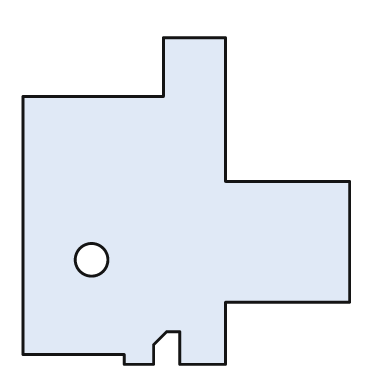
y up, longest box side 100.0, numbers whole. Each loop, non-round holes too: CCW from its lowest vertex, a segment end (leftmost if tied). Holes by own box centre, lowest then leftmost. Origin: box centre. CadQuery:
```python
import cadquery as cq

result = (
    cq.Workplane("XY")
    .moveTo(-19.0, -50.0)
    .lineTo(-10.0, -50.0)
    .lineTo(-10.0, -44.0)
    .lineTo(-6.0, -40.0)
    .lineTo(-2.0, -40.0)
    .lineTo(-2.0, -50.0)
    .lineTo(12.0, -50.0)
    .lineTo(12.0, -31.0)
    .lineTo(50.0, -31.0)
    .lineTo(50.0, 6.0)
    .lineTo(12.0, 6.0)
    .lineTo(12.0, 50.0)
    .lineTo(-7.0, 50.0)
    .lineTo(-7.0, 32.0)
    .lineTo(-50.0, 32.0)
    .lineTo(-50.0, -47.0)
    .lineTo(-19.0, -47.0)
    .close()
    .moveTo(-29.0, -18.0)
    .circle(5.0)
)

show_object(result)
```